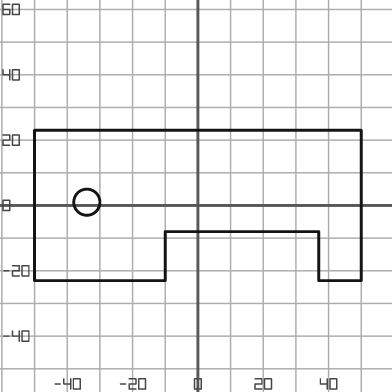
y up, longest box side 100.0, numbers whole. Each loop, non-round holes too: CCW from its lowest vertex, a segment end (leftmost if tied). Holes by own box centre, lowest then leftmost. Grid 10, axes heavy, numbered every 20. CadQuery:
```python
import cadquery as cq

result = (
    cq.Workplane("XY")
    .moveTo(-50.0, -23.0)
    .lineTo(-10.0, -23.0)
    .lineTo(-10.0, -8.0)
    .lineTo(37.0, -8.0)
    .lineTo(37.0, -23.0)
    .lineTo(50.0, -23.0)
    .lineTo(50.0, 23.0)
    .lineTo(-50.0, 23.0)
    .close()
    .moveTo(-34.0, 1.0)
    .circle(4.0)
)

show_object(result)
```